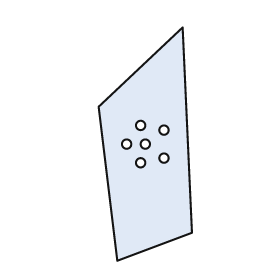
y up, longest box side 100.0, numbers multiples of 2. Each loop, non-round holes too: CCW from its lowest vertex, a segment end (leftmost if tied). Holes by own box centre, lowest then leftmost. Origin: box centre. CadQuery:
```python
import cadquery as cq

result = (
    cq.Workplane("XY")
    .moveTo(-12.0, -50.0)
    .lineTo(20.0, -38.0)
    .lineTo(16.0, 50.0)
    .lineTo(-20.0, 16.0)
    .close()
    .moveTo(-2.0, -8.0)
    .circle(2.0)
    .moveTo(8.0, -6.0)
    .circle(2.0)
    .moveTo(-8.0, 0.0)
    .circle(2.0)
    .moveTo(0.0, 0.0)
    .circle(2.0)
    .moveTo(8.0, 6.0)
    .circle(2.0)
    .moveTo(-2.0, 8.0)
    .circle(2.0)
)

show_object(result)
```